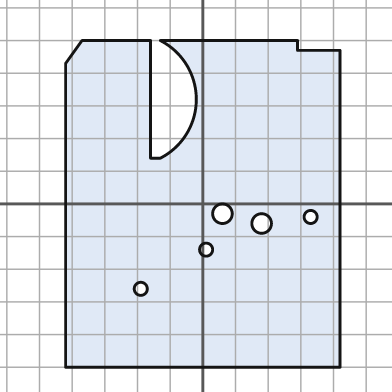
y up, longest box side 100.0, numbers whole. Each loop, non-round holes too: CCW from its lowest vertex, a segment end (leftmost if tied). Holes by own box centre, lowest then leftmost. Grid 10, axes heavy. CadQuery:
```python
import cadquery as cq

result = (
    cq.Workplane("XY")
    .moveTo(-42.0, -50.0)
    .lineTo(42.0, -50.0)
    .lineTo(42.0, 47.0)
    .lineTo(29.0, 47.0)
    .lineTo(29.0, 50.0)
    .lineTo(-13.0, 50.0)
    .threePointArc((-2.0, 32.0), (-13.0, 14.0))
    .lineTo(-16.0, 14.0)
    .lineTo(-16.0, 50.0)
    .lineTo(-37.0, 50.0)
    .lineTo(-42.0, 43.0)
    .close()
    .moveTo(-19.0, -26.0)
    .circle(2.0)
    .moveTo(1.0, -14.0)
    .circle(2.0)
    .moveTo(18.0, -6.0)
    .circle(3.0)
    .moveTo(33.0, -4.0)
    .circle(2.0)
    .moveTo(6.0, -3.0)
    .circle(3.0)
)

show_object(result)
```